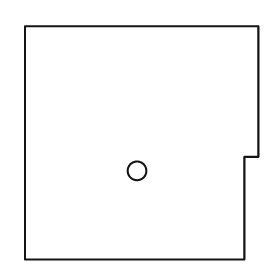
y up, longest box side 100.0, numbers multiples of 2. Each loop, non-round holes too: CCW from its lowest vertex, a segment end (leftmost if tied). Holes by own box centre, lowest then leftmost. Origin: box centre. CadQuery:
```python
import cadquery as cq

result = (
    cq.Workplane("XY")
    .moveTo(-50.0, -50.0)
    .lineTo(44.0, -50.0)
    .lineTo(44.0, -6.0)
    .lineTo(50.0, -6.0)
    .lineTo(50.0, 50.0)
    .lineTo(-50.0, 50.0)
    .close()
    .moveTo(-2.0, -12.0)
    .circle(4.0)
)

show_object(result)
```